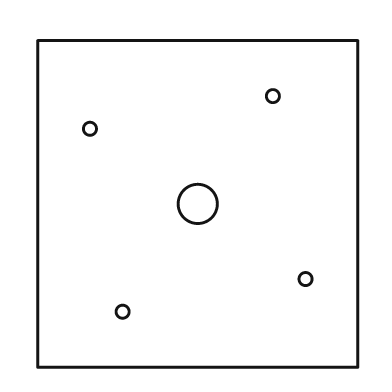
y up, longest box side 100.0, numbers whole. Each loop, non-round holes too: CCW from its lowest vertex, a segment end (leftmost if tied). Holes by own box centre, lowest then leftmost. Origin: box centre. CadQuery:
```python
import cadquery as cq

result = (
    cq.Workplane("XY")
    .moveTo(-49.0, -50.0)
    .lineTo(49.0, -50.0)
    .lineTo(49.0, 50.0)
    .lineTo(-49.0, 50.0)
    .close()
    .moveTo(-23.0, -33.0)
    .circle(2.0)
    .moveTo(33.0, -23.0)
    .circle(2.0)
    .moveTo(0.0, 0.0)
    .circle(6.0)
    .moveTo(-33.0, 23.0)
    .circle(2.0)
    .moveTo(23.0, 33.0)
    .circle(2.0)
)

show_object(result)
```